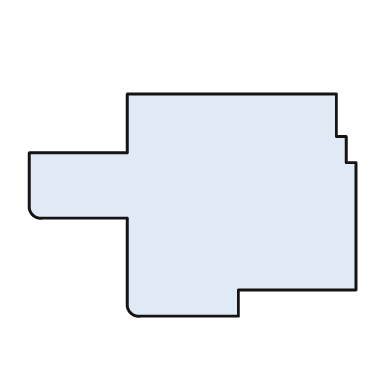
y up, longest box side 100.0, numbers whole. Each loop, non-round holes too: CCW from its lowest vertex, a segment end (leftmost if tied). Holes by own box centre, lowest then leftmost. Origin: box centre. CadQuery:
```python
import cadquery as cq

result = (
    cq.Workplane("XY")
    .moveTo(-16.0, -34.0)
    .lineTo(14.0, -34.0)
    .lineTo(14.0, -26.0)
    .lineTo(50.0, -26.0)
    .lineTo(50.0, 13.0)
    .lineTo(47.0, 13.0)
    .lineTo(47.0, 21.0)
    .lineTo(44.0, 21.0)
    .lineTo(44.0, 34.0)
    .lineTo(-20.0, 34.0)
    .lineTo(-20.0, 16.0)
    .lineTo(-50.0, 16.0)
    .lineTo(-50.0, 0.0)
    .threePointArc((-49.0, -3.0), (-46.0, -4.0))
    .lineTo(-20.0, -4.0)
    .lineTo(-20.0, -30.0)
    .threePointArc((-19.0, -33.0), (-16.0, -34.0))
    .close()
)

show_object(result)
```